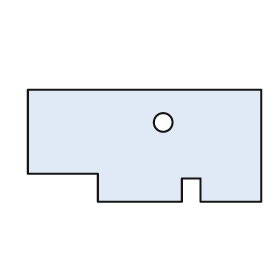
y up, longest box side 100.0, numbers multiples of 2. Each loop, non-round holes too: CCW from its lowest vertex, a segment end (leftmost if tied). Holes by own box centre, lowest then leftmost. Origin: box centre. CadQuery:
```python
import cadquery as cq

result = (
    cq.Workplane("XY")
    .moveTo(-20.0, -24.0)
    .lineTo(16.0, -24.0)
    .lineTo(16.0, -14.0)
    .lineTo(24.0, -14.0)
    .lineTo(24.0, -24.0)
    .lineTo(50.0, -24.0)
    .lineTo(50.0, 24.0)
    .lineTo(-50.0, 24.0)
    .lineTo(-50.0, -12.0)
    .lineTo(-20.0, -12.0)
    .close()
    .moveTo(8.0, 10.0)
    .circle(4.0)
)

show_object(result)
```